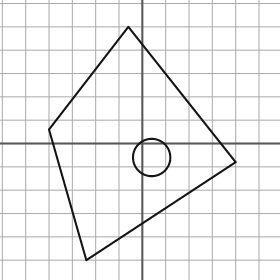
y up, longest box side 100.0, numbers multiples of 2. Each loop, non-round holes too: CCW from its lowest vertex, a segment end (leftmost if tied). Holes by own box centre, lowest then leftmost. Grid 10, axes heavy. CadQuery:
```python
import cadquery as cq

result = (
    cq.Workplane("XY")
    .moveTo(-24.0, -50.0)
    .lineTo(40.0, -8.0)
    .lineTo(-6.0, 50.0)
    .lineTo(-40.0, 6.0)
    .close()
    .moveTo(4.0, -6.0)
    .circle(8.0)
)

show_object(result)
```